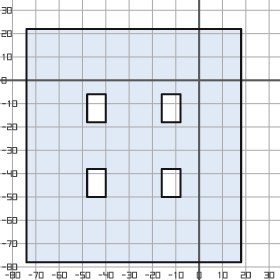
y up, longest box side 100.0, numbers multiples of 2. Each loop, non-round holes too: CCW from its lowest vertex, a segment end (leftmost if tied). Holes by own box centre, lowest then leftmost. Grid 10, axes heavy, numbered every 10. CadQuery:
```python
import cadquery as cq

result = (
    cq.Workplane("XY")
    .moveTo(-74.0, -78.0)
    .lineTo(18.0, -78.0)
    .lineTo(18.0, 22.0)
    .lineTo(-74.0, 22.0)
    .close()
    .moveTo(-48.0, -50.0)
    .lineTo(-40.0, -50.0)
    .lineTo(-40.0, -38.0)
    .lineTo(-48.0, -38.0)
    .close()
    .moveTo(-16.0, -50.0)
    .lineTo(-8.0, -50.0)
    .lineTo(-8.0, -38.0)
    .lineTo(-16.0, -38.0)
    .close()
    .moveTo(-48.0, -18.0)
    .lineTo(-40.0, -18.0)
    .lineTo(-40.0, -6.0)
    .lineTo(-48.0, -6.0)
    .close()
    .moveTo(-16.0, -18.0)
    .lineTo(-8.0, -18.0)
    .lineTo(-8.0, -6.0)
    .lineTo(-16.0, -6.0)
    .close()
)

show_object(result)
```